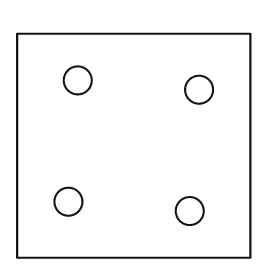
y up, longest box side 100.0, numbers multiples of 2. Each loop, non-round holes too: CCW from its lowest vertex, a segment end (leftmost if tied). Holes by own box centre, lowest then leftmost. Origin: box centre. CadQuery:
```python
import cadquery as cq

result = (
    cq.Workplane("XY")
    .moveTo(-50.0, -48.0)
    .lineTo(50.0, -48.0)
    .lineTo(50.0, 48.0)
    .lineTo(-50.0, 48.0)
    .close()
    .moveTo(24.0, -28.0)
    .circle(6.0)
    .moveTo(-28.0, -24.0)
    .circle(6.0)
    .moveTo(28.0, 24.0)
    .circle(6.0)
    .moveTo(-24.0, 28.0)
    .circle(6.0)
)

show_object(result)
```